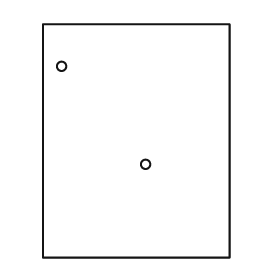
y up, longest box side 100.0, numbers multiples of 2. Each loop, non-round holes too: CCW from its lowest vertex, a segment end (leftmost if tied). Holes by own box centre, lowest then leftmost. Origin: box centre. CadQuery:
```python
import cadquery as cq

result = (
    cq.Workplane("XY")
    .moveTo(-40.0, -50.0)
    .lineTo(40.0, -50.0)
    .lineTo(40.0, 50.0)
    .lineTo(-40.0, 50.0)
    .close()
    .moveTo(4.0, -10.0)
    .circle(2.0)
    .moveTo(-32.0, 32.0)
    .circle(2.0)
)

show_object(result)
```